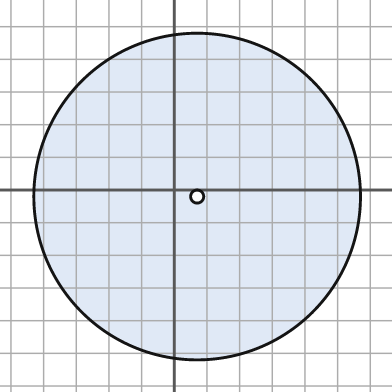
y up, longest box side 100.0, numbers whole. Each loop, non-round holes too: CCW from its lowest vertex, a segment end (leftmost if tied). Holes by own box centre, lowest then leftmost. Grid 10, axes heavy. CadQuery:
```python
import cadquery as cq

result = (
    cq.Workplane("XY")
    .moveTo(7.0, -2.0)
    .circle(50.0)
    .moveTo(7.0, -2.0)
    .circle(2.0)
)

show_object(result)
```